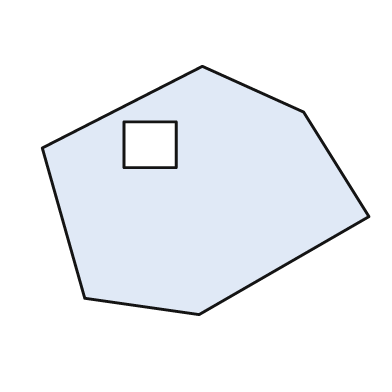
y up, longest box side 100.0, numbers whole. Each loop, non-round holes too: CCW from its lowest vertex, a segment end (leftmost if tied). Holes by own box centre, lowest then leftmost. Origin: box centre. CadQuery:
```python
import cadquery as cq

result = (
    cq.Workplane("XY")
    .moveTo(-2.0, -38.0)
    .lineTo(50.0, -8.0)
    .lineTo(30.0, 24.0)
    .lineTo(-1.0, 38.0)
    .lineTo(-50.0, 13.0)
    .lineTo(-37.0, -33.0)
    .close()
    .moveTo(-25.0, 7.0)
    .lineTo(-9.0, 7.0)
    .lineTo(-9.0, 21.0)
    .lineTo(-25.0, 21.0)
    .close()
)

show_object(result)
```